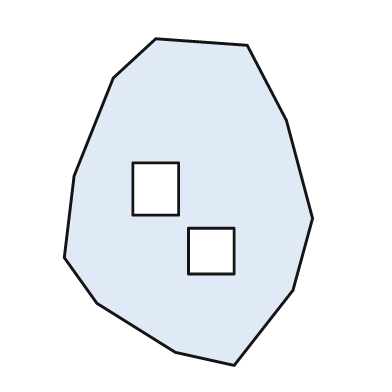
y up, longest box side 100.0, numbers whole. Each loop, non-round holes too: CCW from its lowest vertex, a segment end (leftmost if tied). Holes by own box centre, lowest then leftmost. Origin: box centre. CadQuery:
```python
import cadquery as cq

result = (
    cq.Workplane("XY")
    .moveTo(14.0, -50.0)
    .lineTo(32.0, -27.0)
    .lineTo(38.0, -5.0)
    .lineTo(30.0, 25.0)
    .lineTo(18.0, 48.0)
    .lineTo(-10.0, 50.0)
    .lineTo(-23.0, 38.0)
    .lineTo(-35.0, 8.0)
    .lineTo(-38.0, -17.0)
    .lineTo(-28.0, -31.0)
    .lineTo(-4.0, -46.0)
    .close()
    .moveTo(0.0, -22.0)
    .lineTo(14.0, -22.0)
    .lineTo(14.0, -8.0)
    .lineTo(0.0, -8.0)
    .close()
    .moveTo(-17.0, -4.0)
    .lineTo(-3.0, -4.0)
    .lineTo(-3.0, 12.0)
    .lineTo(-17.0, 12.0)
    .close()
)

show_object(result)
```